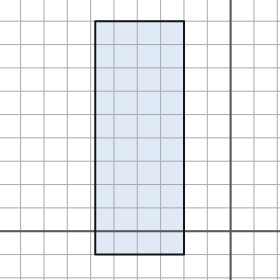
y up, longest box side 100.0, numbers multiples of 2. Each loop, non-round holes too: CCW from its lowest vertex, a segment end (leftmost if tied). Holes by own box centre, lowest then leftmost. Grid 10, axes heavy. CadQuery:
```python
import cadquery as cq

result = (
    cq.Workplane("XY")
    .moveTo(-58.0, -10.0)
    .lineTo(-20.0, -10.0)
    .lineTo(-20.0, 90.0)
    .lineTo(-58.0, 90.0)
    .close()
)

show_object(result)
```